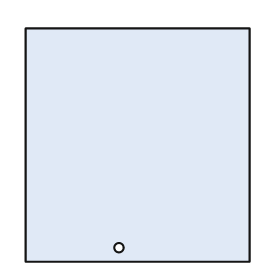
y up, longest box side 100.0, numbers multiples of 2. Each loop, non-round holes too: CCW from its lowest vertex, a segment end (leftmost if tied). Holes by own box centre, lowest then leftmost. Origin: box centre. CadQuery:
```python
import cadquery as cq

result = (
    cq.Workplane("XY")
    .moveTo(-48.0, -50.0)
    .lineTo(48.0, -50.0)
    .lineTo(48.0, 50.0)
    .lineTo(-48.0, 50.0)
    .close()
    .moveTo(-8.0, -44.0)
    .circle(2.0)
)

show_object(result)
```